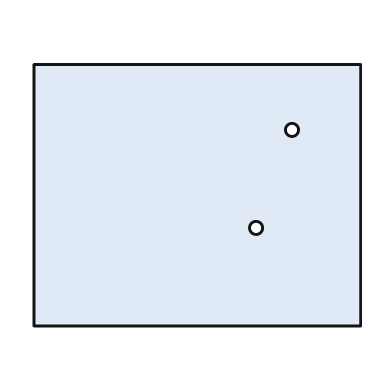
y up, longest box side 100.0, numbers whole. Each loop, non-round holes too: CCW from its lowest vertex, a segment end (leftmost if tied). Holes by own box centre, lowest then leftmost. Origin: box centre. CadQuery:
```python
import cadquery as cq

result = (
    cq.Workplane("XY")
    .moveTo(-50.0, -40.0)
    .lineTo(50.0, -40.0)
    .lineTo(50.0, 40.0)
    .lineTo(-50.0, 40.0)
    .close()
    .moveTo(18.0, -10.0)
    .circle(2.0)
    .moveTo(29.0, 20.0)
    .circle(2.0)
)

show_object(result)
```